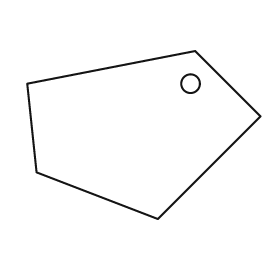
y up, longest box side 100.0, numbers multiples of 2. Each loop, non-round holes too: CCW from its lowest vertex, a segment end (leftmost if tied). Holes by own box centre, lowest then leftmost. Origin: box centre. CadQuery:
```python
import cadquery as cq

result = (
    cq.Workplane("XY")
    .moveTo(6.0, -36.0)
    .lineTo(50.0, 8.0)
    .lineTo(22.0, 36.0)
    .lineTo(-50.0, 22.0)
    .lineTo(-46.0, -16.0)
    .close()
    .moveTo(20.0, 22.0)
    .circle(4.0)
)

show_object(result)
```